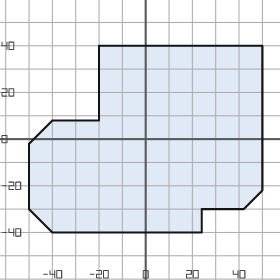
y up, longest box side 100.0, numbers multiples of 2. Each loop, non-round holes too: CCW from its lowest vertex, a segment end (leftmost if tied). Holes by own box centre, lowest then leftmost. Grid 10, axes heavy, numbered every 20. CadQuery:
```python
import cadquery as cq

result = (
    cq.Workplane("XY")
    .moveTo(-40.0, -40.0)
    .lineTo(24.0, -40.0)
    .lineTo(24.0, -30.0)
    .lineTo(42.0, -30.0)
    .lineTo(50.0, -22.0)
    .lineTo(50.0, 40.0)
    .lineTo(-20.0, 40.0)
    .lineTo(-20.0, 8.0)
    .lineTo(-40.0, 8.0)
    .lineTo(-50.0, -2.0)
    .lineTo(-50.0, -30.0)
    .close()
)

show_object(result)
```